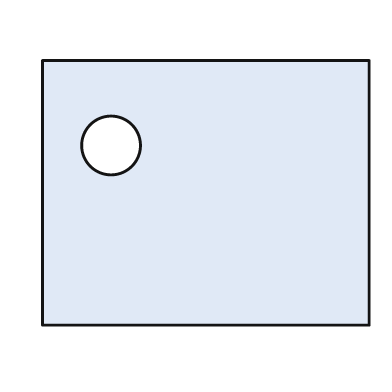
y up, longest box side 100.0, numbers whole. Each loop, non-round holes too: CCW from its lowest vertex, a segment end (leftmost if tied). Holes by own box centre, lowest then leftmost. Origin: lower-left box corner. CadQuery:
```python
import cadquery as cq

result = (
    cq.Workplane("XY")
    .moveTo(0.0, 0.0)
    .lineTo(100.0, 0.0)
    .lineTo(100.0, 81.0)
    .lineTo(0.0, 81.0)
    .close()
    .moveTo(21.0, 55.0)
    .circle(9.0)
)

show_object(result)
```